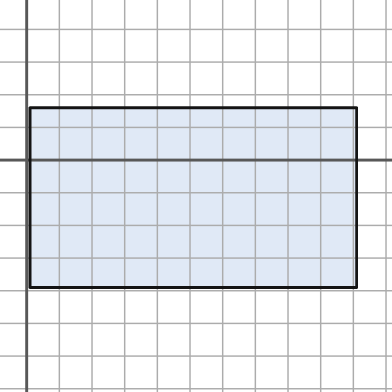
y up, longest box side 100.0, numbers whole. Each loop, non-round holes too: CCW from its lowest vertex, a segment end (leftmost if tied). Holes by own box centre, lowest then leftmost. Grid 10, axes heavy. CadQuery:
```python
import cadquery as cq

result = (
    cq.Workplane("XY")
    .moveTo(1.0, -39.0)
    .lineTo(101.0, -39.0)
    .lineTo(101.0, 16.0)
    .lineTo(1.0, 16.0)
    .close()
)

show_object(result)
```